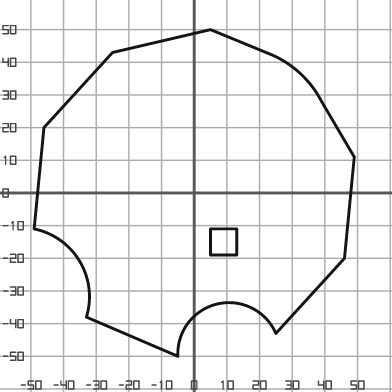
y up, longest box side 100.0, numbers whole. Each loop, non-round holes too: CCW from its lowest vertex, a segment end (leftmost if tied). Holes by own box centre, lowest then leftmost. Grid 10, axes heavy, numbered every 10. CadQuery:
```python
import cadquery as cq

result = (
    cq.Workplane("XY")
    .moveTo(-5.0, -50.0)
    .threePointArc((7.0, -34.0), (25.0, -43.0))
    .lineTo(46.0, -20.0)
    .lineTo(49.0, 11.0)
    .lineTo(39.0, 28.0)
    .threePointArc((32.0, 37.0), (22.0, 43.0))
    .lineTo(5.0, 50.0)
    .lineTo(-25.0, 43.0)
    .lineTo(-46.0, 20.0)
    .lineTo(-49.0, -11.0)
    .threePointArc((-35.0, -21.0), (-33.0, -38.0))
    .close()
    .moveTo(5.0, -19.0)
    .lineTo(13.0, -19.0)
    .lineTo(13.0, -11.0)
    .lineTo(5.0, -11.0)
    .close()
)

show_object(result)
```